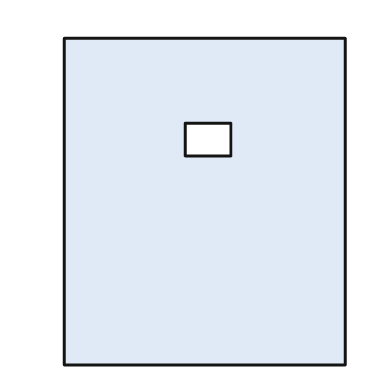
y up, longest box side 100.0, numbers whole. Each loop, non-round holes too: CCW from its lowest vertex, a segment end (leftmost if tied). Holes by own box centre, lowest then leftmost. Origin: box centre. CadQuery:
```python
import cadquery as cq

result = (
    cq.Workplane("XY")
    .moveTo(-43.0, -50.0)
    .lineTo(43.0, -50.0)
    .lineTo(43.0, 50.0)
    .lineTo(-43.0, 50.0)
    .close()
    .moveTo(-6.0, 14.0)
    .lineTo(8.0, 14.0)
    .lineTo(8.0, 24.0)
    .lineTo(-6.0, 24.0)
    .close()
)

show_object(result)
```